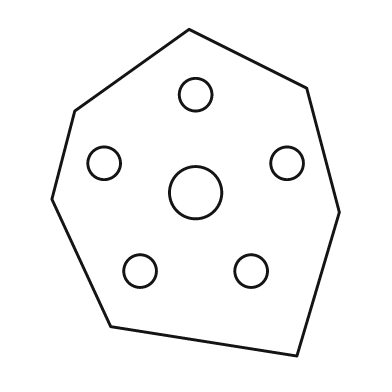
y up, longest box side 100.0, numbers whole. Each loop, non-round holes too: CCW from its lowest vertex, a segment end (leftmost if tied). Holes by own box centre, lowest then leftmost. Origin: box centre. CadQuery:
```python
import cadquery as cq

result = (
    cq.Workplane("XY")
    .moveTo(31.0, -50.0)
    .lineTo(44.0, -6.0)
    .lineTo(34.0, 32.0)
    .lineTo(-2.0, 50.0)
    .lineTo(-37.0, 25.0)
    .lineTo(-44.0, -2.0)
    .lineTo(-26.0, -41.0)
    .close()
    .moveTo(-17.0, -24.0)
    .circle(5.0)
    .moveTo(17.0, -24.0)
    .circle(5.0)
    .moveTo(0.0, 0.0)
    .circle(8.0)
    .moveTo(-28.0, 9.0)
    .circle(5.0)
    .moveTo(28.0, 9.0)
    .circle(5.0)
    .moveTo(0.0, 30.0)
    .circle(5.0)
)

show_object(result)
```